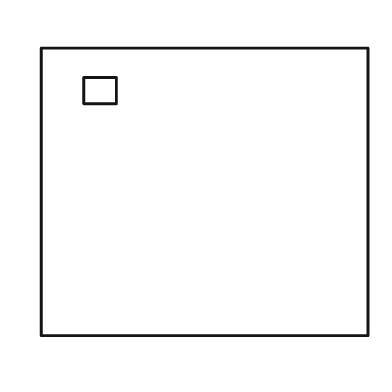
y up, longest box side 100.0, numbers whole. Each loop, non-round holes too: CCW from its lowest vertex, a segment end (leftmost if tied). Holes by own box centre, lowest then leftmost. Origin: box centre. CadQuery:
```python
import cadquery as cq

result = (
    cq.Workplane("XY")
    .moveTo(-50.0, -44.0)
    .lineTo(50.0, -44.0)
    .lineTo(50.0, 44.0)
    .lineTo(-50.0, 44.0)
    .close()
    .moveTo(-37.0, 27.0)
    .lineTo(-27.0, 27.0)
    .lineTo(-27.0, 35.0)
    .lineTo(-37.0, 35.0)
    .close()
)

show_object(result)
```